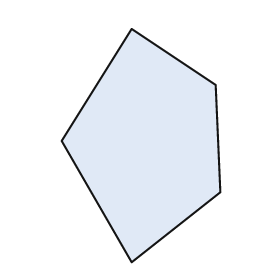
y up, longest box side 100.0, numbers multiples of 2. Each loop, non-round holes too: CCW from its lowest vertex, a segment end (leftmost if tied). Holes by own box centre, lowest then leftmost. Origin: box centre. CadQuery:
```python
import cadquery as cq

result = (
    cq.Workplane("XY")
    .moveTo(-4.0, -50.0)
    .lineTo(34.0, -20.0)
    .lineTo(32.0, 26.0)
    .lineTo(-4.0, 50.0)
    .lineTo(-34.0, 2.0)
    .close()
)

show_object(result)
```